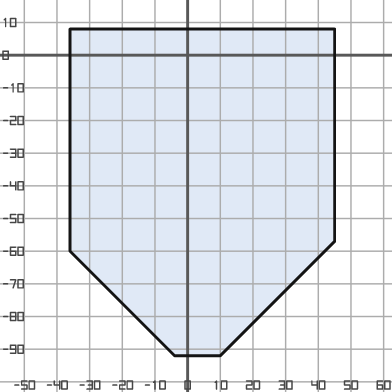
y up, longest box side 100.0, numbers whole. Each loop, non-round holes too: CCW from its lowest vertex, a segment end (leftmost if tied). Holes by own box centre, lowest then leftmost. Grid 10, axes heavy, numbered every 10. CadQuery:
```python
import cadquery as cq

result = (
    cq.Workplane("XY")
    .moveTo(-4.0, -92.0)
    .lineTo(10.0, -92.0)
    .lineTo(45.0, -57.0)
    .lineTo(45.0, 8.0)
    .lineTo(-36.0, 8.0)
    .lineTo(-36.0, -60.0)
    .close()
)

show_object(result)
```